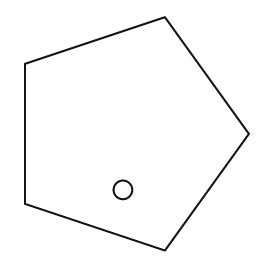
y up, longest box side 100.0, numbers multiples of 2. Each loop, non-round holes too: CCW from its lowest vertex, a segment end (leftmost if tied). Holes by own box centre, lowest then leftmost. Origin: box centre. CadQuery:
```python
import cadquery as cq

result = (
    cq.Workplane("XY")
    .moveTo(12.0, -50.0)
    .lineTo(48.0, 0.0)
    .lineTo(12.0, 50.0)
    .lineTo(-48.0, 30.0)
    .lineTo(-48.0, -30.0)
    .close()
    .moveTo(-6.0, -24.0)
    .circle(4.0)
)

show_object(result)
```